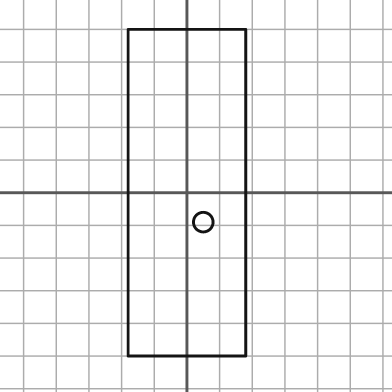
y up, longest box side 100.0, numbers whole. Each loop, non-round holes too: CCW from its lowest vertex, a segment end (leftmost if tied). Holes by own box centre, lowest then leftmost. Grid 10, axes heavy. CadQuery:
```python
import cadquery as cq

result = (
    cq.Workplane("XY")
    .moveTo(-18.0, -50.0)
    .lineTo(18.0, -50.0)
    .lineTo(18.0, 50.0)
    .lineTo(-18.0, 50.0)
    .close()
    .moveTo(5.0, -9.0)
    .circle(3.0)
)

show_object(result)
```